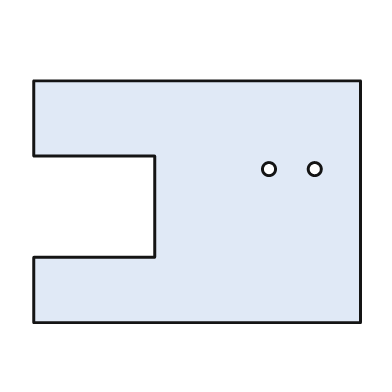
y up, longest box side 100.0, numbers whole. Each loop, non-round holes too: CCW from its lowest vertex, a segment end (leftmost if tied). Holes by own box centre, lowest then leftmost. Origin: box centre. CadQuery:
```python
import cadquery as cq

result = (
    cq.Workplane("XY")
    .moveTo(-50.0, -37.0)
    .lineTo(50.0, -37.0)
    .lineTo(50.0, 37.0)
    .lineTo(-50.0, 37.0)
    .lineTo(-50.0, 14.0)
    .lineTo(-13.0, 14.0)
    .lineTo(-13.0, -17.0)
    .lineTo(-50.0, -17.0)
    .close()
    .moveTo(22.0, 10.0)
    .circle(2.0)
    .moveTo(36.0, 10.0)
    .circle(2.0)
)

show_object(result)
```